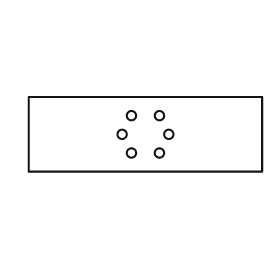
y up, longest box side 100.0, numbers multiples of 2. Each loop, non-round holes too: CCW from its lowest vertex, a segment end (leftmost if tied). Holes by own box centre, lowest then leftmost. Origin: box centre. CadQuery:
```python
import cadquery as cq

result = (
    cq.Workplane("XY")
    .moveTo(-50.0, -16.0)
    .lineTo(50.0, -16.0)
    .lineTo(50.0, 16.0)
    .lineTo(-50.0, 16.0)
    .close()
    .moveTo(-6.0, -8.0)
    .circle(2.0)
    .moveTo(6.0, -8.0)
    .circle(2.0)
    .moveTo(-10.0, 0.0)
    .circle(2.0)
    .moveTo(10.0, 0.0)
    .circle(2.0)
    .moveTo(-6.0, 8.0)
    .circle(2.0)
    .moveTo(6.0, 8.0)
    .circle(2.0)
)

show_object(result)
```